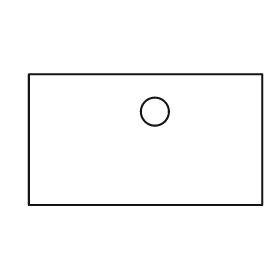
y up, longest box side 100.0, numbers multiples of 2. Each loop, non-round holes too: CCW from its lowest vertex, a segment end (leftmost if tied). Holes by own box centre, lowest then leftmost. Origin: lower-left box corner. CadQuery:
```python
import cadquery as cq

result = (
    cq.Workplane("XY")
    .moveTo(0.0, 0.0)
    .lineTo(100.0, 0.0)
    .lineTo(100.0, 56.0)
    .lineTo(0.0, 56.0)
    .close()
    .moveTo(54.0, 40.0)
    .circle(6.0)
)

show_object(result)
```